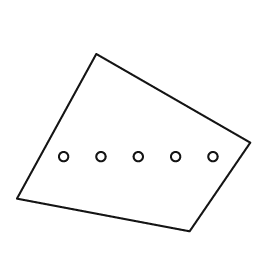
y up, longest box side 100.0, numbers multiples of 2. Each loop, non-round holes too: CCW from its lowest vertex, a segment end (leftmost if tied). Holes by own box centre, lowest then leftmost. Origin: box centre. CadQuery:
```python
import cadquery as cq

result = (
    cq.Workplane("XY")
    .moveTo(24.0, -38.0)
    .lineTo(50.0, 0.0)
    .lineTo(-16.0, 38.0)
    .lineTo(-50.0, -24.0)
    .close()
    .moveTo(-30.0, -6.0)
    .circle(2.0)
    .moveTo(-14.0, -6.0)
    .circle(2.0)
    .moveTo(2.0, -6.0)
    .circle(2.0)
    .moveTo(18.0, -6.0)
    .circle(2.0)
    .moveTo(34.0, -6.0)
    .circle(2.0)
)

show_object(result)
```